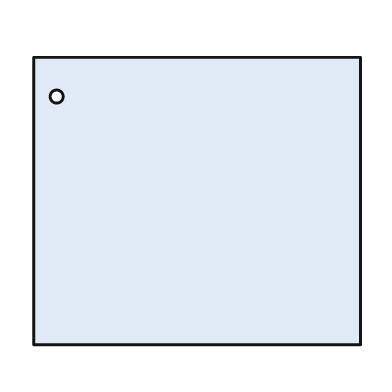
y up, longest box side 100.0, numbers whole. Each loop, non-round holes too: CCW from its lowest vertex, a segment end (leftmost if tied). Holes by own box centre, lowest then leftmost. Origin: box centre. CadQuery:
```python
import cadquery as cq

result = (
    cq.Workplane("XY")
    .moveTo(-50.0, -44.0)
    .lineTo(50.0, -44.0)
    .lineTo(50.0, 44.0)
    .lineTo(-50.0, 44.0)
    .close()
    .moveTo(-43.0, 32.0)
    .circle(2.0)
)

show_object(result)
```